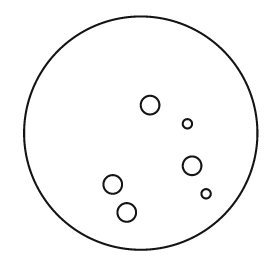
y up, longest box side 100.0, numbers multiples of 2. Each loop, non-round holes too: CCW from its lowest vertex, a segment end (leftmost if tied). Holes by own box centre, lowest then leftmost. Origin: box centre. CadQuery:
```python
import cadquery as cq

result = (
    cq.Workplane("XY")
    .moveTo(0.0, 0.0)
    .circle(50.0)
    .moveTo(-6.0, -34.0)
    .circle(4.0)
    .moveTo(28.0, -26.0)
    .circle(2.0)
    .moveTo(-12.0, -22.0)
    .circle(4.0)
    .moveTo(22.0, -14.0)
    .circle(4.0)
    .moveTo(20.0, 4.0)
    .circle(2.0)
    .moveTo(4.0, 12.0)
    .circle(4.0)
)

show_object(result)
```